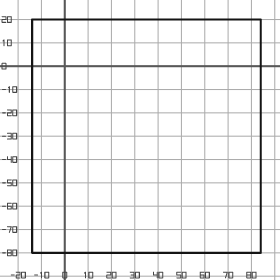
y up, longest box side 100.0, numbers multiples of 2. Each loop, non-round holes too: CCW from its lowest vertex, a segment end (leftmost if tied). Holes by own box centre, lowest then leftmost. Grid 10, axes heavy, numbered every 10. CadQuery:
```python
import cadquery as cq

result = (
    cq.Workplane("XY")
    .moveTo(-14.0, -80.0)
    .lineTo(84.0, -80.0)
    .lineTo(84.0, 20.0)
    .lineTo(-14.0, 20.0)
    .close()
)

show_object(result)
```